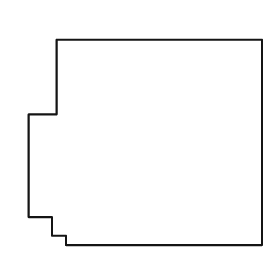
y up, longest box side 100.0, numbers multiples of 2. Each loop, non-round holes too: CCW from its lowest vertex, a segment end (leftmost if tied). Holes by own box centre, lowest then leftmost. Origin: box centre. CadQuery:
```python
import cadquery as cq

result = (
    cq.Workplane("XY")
    .moveTo(-34.0, -44.0)
    .lineTo(50.0, -44.0)
    .lineTo(50.0, 44.0)
    .lineTo(-38.0, 44.0)
    .lineTo(-38.0, 12.0)
    .lineTo(-50.0, 12.0)
    .lineTo(-50.0, -32.0)
    .lineTo(-40.0, -32.0)
    .lineTo(-40.0, -40.0)
    .lineTo(-34.0, -40.0)
    .close()
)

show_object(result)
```